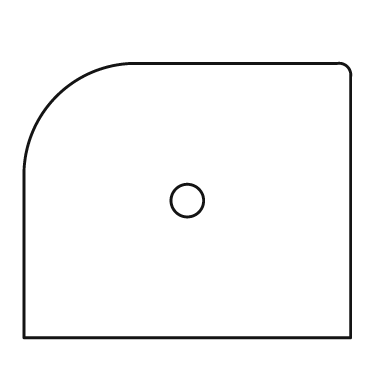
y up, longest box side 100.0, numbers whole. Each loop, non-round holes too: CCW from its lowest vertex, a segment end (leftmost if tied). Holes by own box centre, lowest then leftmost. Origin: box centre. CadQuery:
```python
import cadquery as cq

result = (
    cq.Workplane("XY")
    .moveTo(-50.0, -42.0)
    .lineTo(50.0, -42.0)
    .lineTo(50.0, 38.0)
    .threePointArc((49.0, 41.0), (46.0, 42.0))
    .lineTo(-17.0, 42.0)
    .threePointArc((-40.0, 32.0), (-50.0, 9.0))
    .close()
    .moveTo(0.0, 0.0)
    .circle(5.0)
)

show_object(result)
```